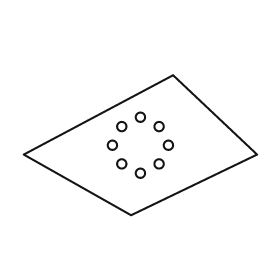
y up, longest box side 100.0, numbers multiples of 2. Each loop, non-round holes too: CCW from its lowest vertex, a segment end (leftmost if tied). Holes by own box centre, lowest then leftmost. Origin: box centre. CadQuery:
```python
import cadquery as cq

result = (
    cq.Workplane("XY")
    .moveTo(-4.0, -30.0)
    .lineTo(50.0, -4.0)
    .lineTo(14.0, 30.0)
    .lineTo(-50.0, -4.0)
    .close()
    .moveTo(0.0, -12.0)
    .circle(2.0)
    .moveTo(-8.0, -8.0)
    .circle(2.0)
    .moveTo(8.0, -8.0)
    .circle(2.0)
    .moveTo(-12.0, 0.0)
    .circle(2.0)
    .moveTo(12.0, 0.0)
    .circle(2.0)
    .moveTo(-8.0, 8.0)
    .circle(2.0)
    .moveTo(8.0, 8.0)
    .circle(2.0)
    .moveTo(0.0, 12.0)
    .circle(2.0)
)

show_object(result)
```